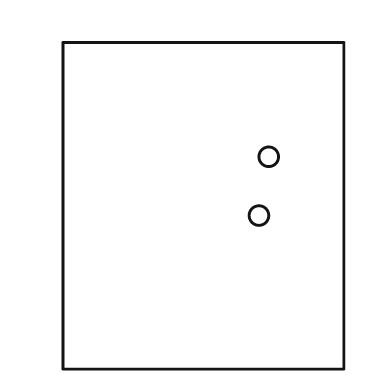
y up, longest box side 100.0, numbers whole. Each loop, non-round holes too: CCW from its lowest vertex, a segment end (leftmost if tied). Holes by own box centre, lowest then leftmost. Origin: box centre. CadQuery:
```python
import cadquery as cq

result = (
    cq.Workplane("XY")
    .moveTo(-43.0, -50.0)
    .lineTo(43.0, -50.0)
    .lineTo(43.0, 50.0)
    .lineTo(-43.0, 50.0)
    .close()
    .moveTo(17.0, -3.0)
    .circle(3.0)
    .moveTo(20.0, 15.0)
    .circle(3.0)
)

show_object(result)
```